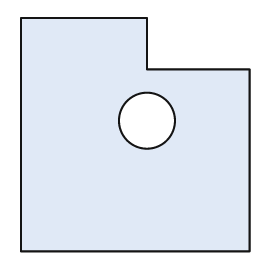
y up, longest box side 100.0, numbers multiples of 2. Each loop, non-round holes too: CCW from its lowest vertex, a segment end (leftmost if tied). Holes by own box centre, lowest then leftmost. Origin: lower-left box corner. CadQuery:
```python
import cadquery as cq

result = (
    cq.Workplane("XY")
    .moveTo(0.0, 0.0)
    .lineTo(98.0, 0.0)
    .lineTo(98.0, 78.0)
    .lineTo(54.0, 78.0)
    .lineTo(54.0, 100.0)
    .lineTo(0.0, 100.0)
    .close()
    .moveTo(54.0, 56.0)
    .circle(12.0)
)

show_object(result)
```